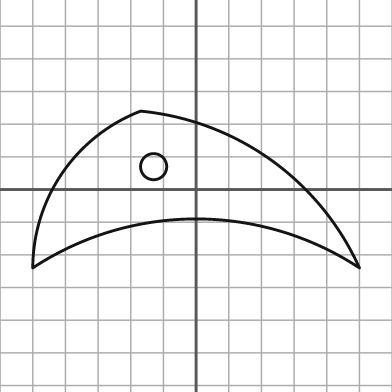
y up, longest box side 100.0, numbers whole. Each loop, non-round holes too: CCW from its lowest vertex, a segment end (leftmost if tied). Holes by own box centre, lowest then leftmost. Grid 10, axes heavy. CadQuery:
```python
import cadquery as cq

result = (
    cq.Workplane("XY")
    .moveTo(-50.0, -24.0)
    .threePointArc((0.0, -9.0), (50.0, -24.0))
    .threePointArc((23.0, 9.0), (-17.0, 24.0))
    .threePointArc((-41.0, 5.0), (-50.0, -24.0))
    .close()
    .moveTo(-13.0, 7.0)
    .circle(4.0)
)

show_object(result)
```